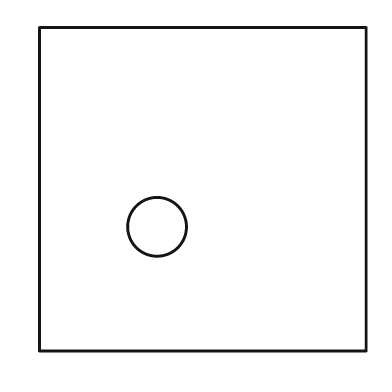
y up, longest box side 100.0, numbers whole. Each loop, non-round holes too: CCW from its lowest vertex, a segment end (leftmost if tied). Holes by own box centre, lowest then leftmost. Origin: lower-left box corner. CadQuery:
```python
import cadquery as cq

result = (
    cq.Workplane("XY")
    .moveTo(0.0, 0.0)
    .lineTo(100.0, 0.0)
    .lineTo(100.0, 99.0)
    .lineTo(0.0, 99.0)
    .close()
    .moveTo(36.0, 38.0)
    .circle(9.0)
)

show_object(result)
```